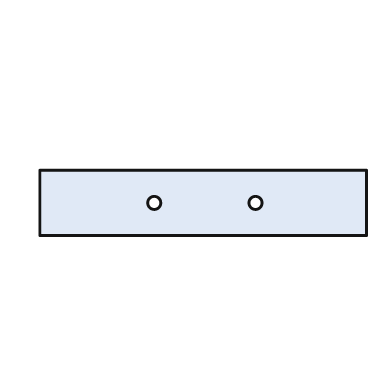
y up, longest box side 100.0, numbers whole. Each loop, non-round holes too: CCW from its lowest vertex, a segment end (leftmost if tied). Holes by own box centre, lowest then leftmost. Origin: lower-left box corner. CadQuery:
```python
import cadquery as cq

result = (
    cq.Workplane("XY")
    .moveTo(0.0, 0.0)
    .lineTo(100.0, 0.0)
    .lineTo(100.0, 20.0)
    .lineTo(0.0, 20.0)
    .close()
    .moveTo(35.0, 10.0)
    .circle(2.0)
    .moveTo(66.0, 10.0)
    .circle(2.0)
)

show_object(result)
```